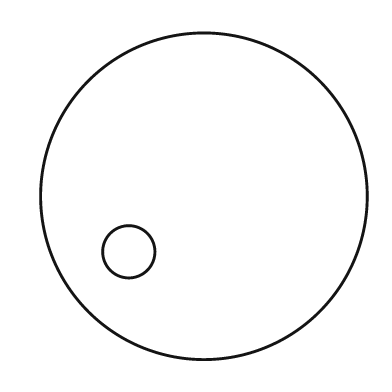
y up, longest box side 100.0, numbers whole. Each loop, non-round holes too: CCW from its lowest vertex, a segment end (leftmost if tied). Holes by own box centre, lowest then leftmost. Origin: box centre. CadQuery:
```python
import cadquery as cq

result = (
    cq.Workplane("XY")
    .moveTo(0.0, 0.0)
    .circle(50.0)
    .moveTo(-23.0, -17.0)
    .circle(8.0)
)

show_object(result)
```